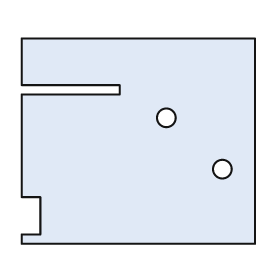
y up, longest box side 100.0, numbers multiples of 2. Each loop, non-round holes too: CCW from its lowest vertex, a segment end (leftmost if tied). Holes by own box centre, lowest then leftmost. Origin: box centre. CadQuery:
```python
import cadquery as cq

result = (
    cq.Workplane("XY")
    .moveTo(-50.0, -44.0)
    .lineTo(50.0, -44.0)
    .lineTo(50.0, 44.0)
    .lineTo(-50.0, 44.0)
    .lineTo(-50.0, 24.0)
    .lineTo(-8.0, 24.0)
    .lineTo(-8.0, 20.0)
    .lineTo(-50.0, 20.0)
    .lineTo(-50.0, -24.0)
    .lineTo(-42.0, -24.0)
    .lineTo(-42.0, -40.0)
    .lineTo(-50.0, -40.0)
    .close()
    .moveTo(36.0, -12.0)
    .circle(4.0)
    .moveTo(12.0, 10.0)
    .circle(4.0)
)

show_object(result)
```